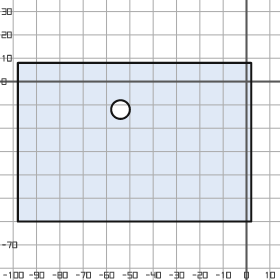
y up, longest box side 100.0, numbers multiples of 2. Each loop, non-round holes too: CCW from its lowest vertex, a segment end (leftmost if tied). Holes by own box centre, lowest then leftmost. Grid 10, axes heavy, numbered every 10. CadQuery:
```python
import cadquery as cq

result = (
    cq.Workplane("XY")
    .moveTo(-98.0, -60.0)
    .lineTo(2.0, -60.0)
    .lineTo(2.0, 8.0)
    .lineTo(-98.0, 8.0)
    .close()
    .moveTo(-54.0, -12.0)
    .circle(4.0)
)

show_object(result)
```